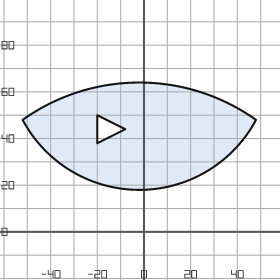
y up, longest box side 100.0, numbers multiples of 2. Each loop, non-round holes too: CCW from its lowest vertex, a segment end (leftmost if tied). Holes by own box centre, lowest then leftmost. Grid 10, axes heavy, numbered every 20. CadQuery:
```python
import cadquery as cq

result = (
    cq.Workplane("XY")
    .moveTo(-52.0, 48.0)
    .threePointArc((-2.0, 18.0), (48.0, 48.0))
    .threePointArc((-2.0, 64.0), (-52.0, 48.0))
    .close()
    .moveTo(-20.0, 38.0)
    .lineTo(-8.0, 44.0)
    .lineTo(-20.0, 50.0)
    .close()
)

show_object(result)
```